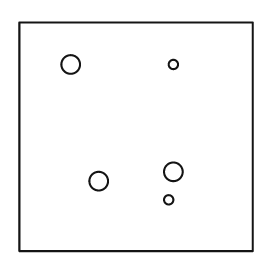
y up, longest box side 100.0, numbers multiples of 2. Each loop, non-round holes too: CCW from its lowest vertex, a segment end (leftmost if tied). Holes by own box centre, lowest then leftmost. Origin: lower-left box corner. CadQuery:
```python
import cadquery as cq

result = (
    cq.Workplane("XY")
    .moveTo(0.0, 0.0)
    .lineTo(100.0, 0.0)
    .lineTo(100.0, 98.0)
    .lineTo(0.0, 98.0)
    .close()
    .moveTo(64.0, 22.0)
    .circle(2.0)
    .moveTo(34.0, 30.0)
    .circle(4.0)
    .moveTo(66.0, 34.0)
    .circle(4.0)
    .moveTo(22.0, 80.0)
    .circle(4.0)
    .moveTo(66.0, 80.0)
    .circle(2.0)
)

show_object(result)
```